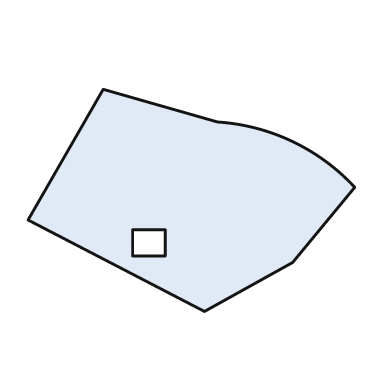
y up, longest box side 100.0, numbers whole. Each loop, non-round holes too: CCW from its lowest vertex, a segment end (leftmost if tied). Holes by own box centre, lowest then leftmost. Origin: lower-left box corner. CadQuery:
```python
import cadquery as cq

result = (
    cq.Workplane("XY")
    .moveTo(54.0, 0.0)
    .lineTo(81.0, 15.0)
    .lineTo(100.0, 38.0)
    .threePointArc((81.0, 52.0), (58.0, 58.0))
    .lineTo(23.0, 68.0)
    .lineTo(0.0, 28.0)
    .close()
    .moveTo(32.0, 17.0)
    .lineTo(42.0, 17.0)
    .lineTo(42.0, 25.0)
    .lineTo(32.0, 25.0)
    .close()
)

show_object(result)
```